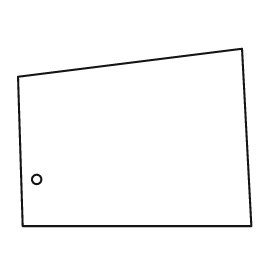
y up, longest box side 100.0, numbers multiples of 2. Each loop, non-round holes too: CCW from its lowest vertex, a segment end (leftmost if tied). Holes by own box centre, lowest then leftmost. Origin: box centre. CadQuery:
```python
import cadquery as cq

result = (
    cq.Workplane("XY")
    .moveTo(-48.0, -38.0)
    .lineTo(50.0, -38.0)
    .lineTo(46.0, 38.0)
    .lineTo(-50.0, 26.0)
    .close()
    .moveTo(-42.0, -18.0)
    .circle(2.0)
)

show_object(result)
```